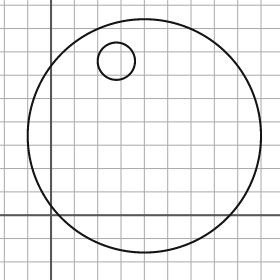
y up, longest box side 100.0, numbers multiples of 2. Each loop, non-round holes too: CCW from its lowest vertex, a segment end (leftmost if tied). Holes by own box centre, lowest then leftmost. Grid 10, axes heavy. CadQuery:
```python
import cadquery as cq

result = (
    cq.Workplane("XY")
    .moveTo(40.0, 34.0)
    .circle(50.0)
    .moveTo(28.0, 66.0)
    .circle(8.0)
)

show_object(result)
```